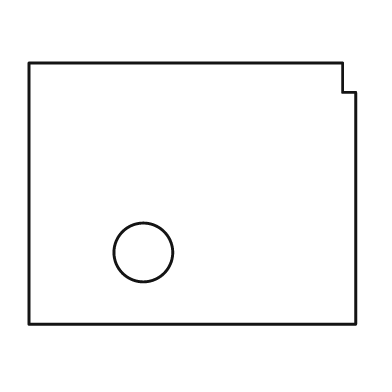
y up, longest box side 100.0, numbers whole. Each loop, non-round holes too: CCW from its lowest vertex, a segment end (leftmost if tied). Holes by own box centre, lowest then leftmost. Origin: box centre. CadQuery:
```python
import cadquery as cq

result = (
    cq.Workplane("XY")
    .moveTo(-50.0, -40.0)
    .lineTo(50.0, -40.0)
    .lineTo(50.0, 31.0)
    .lineTo(46.0, 31.0)
    .lineTo(46.0, 40.0)
    .lineTo(-50.0, 40.0)
    .close()
    .moveTo(-15.0, -18.0)
    .circle(9.0)
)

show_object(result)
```